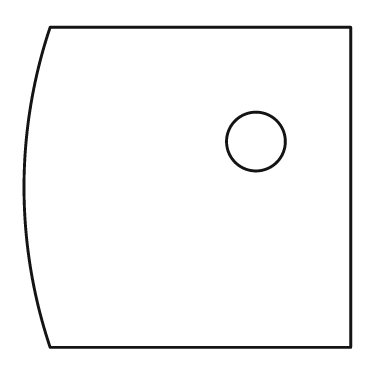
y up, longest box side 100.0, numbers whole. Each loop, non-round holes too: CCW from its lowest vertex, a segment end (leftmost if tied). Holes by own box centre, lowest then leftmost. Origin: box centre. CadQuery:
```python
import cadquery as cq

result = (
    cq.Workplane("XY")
    .moveTo(-42.0, -49.0)
    .lineTo(50.0, -49.0)
    .lineTo(50.0, 49.0)
    .lineTo(-42.0, 49.0)
    .threePointArc((-50.0, 0.0), (-42.0, -49.0))
    .close()
    .moveTo(21.0, 14.0)
    .circle(9.0)
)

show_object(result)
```